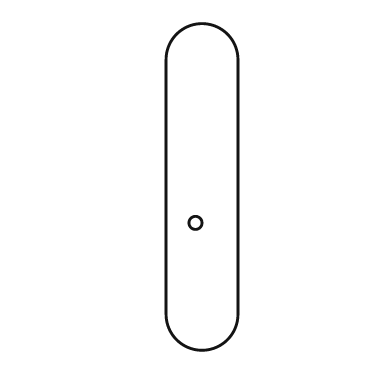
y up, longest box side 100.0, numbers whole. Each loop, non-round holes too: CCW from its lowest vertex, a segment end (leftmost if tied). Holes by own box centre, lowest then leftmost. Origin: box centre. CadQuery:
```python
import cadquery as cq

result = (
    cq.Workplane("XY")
    .moveTo(-11.0, -39.0)
    .threePointArc((0.0, -50.0), (11.0, -39.0))
    .lineTo(11.0, 39.0)
    .threePointArc((0.0, 50.0), (-11.0, 39.0))
    .close()
    .moveTo(-2.0, -11.0)
    .circle(2.0)
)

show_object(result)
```